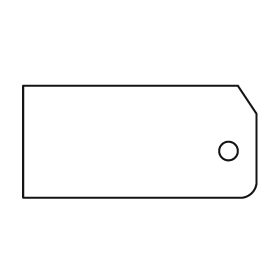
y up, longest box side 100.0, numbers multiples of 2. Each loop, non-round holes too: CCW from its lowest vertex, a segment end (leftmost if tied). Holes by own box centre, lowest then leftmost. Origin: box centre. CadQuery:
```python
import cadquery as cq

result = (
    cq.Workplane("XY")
    .moveTo(-50.0, -24.0)
    .lineTo(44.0, -24.0)
    .threePointArc((48.0, -22.0), (50.0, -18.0))
    .lineTo(50.0, 12.0)
    .lineTo(42.0, 24.0)
    .lineTo(-50.0, 24.0)
    .close()
    .moveTo(38.0, -4.0)
    .circle(4.0)
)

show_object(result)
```